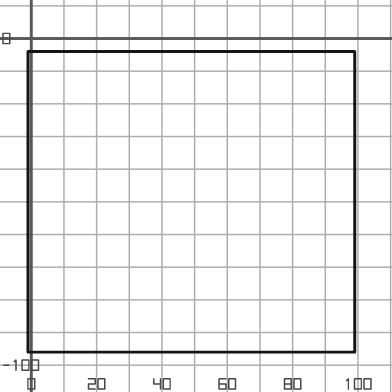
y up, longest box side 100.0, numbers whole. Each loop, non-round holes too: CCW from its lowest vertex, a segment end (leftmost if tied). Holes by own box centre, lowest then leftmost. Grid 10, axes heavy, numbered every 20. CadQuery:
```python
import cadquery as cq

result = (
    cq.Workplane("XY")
    .moveTo(-1.0, -96.0)
    .lineTo(99.0, -96.0)
    .lineTo(99.0, -4.0)
    .lineTo(-1.0, -4.0)
    .close()
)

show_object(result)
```